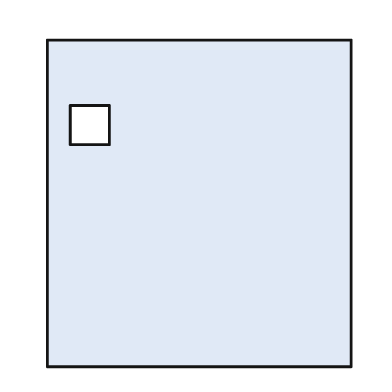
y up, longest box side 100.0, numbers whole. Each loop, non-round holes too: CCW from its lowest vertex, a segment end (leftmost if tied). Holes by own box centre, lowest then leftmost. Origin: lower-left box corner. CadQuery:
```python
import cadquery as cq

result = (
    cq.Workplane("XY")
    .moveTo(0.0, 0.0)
    .lineTo(93.0, 0.0)
    .lineTo(93.0, 100.0)
    .lineTo(0.0, 100.0)
    .close()
    .moveTo(7.0, 68.0)
    .lineTo(19.0, 68.0)
    .lineTo(19.0, 80.0)
    .lineTo(7.0, 80.0)
    .close()
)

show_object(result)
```